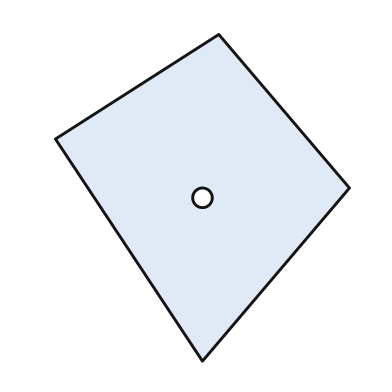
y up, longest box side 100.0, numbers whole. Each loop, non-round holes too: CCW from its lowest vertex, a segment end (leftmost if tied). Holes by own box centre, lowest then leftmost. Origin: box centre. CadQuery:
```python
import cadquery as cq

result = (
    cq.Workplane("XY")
    .moveTo(0.0, -50.0)
    .lineTo(45.0, 3.0)
    .lineTo(5.0, 50.0)
    .lineTo(-45.0, 18.0)
    .close()
    .moveTo(0.0, 0.0)
    .circle(3.0)
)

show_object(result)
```